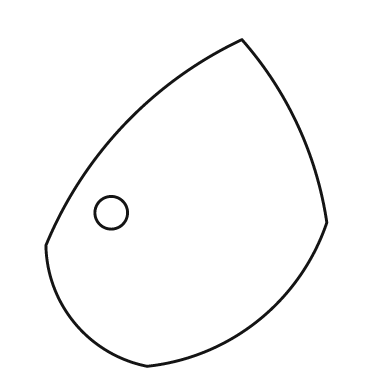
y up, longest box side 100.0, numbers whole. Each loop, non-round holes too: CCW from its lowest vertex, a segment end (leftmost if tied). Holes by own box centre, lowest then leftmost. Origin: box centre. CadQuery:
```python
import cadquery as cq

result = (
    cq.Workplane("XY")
    .moveTo(-12.0, -50.0)
    .threePointArc((22.0, -36.0), (43.0, -6.0))
    .threePointArc((34.0, 24.0), (17.0, 50.0))
    .threePointArc((-19.0, 24.0), (-43.0, -13.0))
    .threePointArc((-34.0, -37.0), (-12.0, -50.0))
    .close()
    .moveTo(-23.0, -3.0)
    .circle(5.0)
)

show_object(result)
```